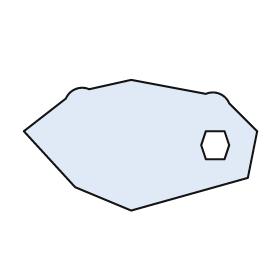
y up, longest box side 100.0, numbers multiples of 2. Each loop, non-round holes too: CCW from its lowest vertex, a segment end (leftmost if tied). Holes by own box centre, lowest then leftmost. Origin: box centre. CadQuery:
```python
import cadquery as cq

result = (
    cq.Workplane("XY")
    .moveTo(-4.0, -28.0)
    .lineTo(46.0, -14.0)
    .lineTo(50.0, 6.0)
    .lineTo(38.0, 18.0)
    .threePointArc((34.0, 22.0), (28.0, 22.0))
    .lineTo(-4.0, 28.0)
    .lineTo(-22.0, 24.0)
    .threePointArc((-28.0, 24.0), (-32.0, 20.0))
    .lineTo(-50.0, 6.0)
    .lineTo(-28.0, -18.0)
    .close()
    .moveTo(28.0, -6.0)
    .lineTo(36.0, -6.0)
    .lineTo(38.0, 0.0)
    .lineTo(36.0, 6.0)
    .lineTo(28.0, 6.0)
    .lineTo(26.0, 0.0)
    .close()
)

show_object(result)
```